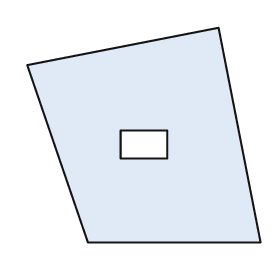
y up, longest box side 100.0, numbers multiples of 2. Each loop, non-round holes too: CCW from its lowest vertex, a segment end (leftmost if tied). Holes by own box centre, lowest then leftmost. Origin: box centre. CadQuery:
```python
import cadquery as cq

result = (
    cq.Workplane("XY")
    .moveTo(-24.0, -46.0)
    .lineTo(50.0, -46.0)
    .lineTo(32.0, 46.0)
    .lineTo(-50.0, 30.0)
    .close()
    .moveTo(-10.0, -10.0)
    .lineTo(10.0, -10.0)
    .lineTo(10.0, 2.0)
    .lineTo(-10.0, 2.0)
    .close()
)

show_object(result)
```